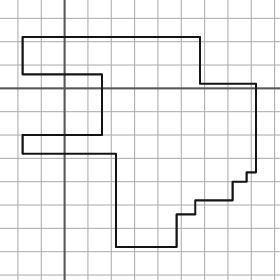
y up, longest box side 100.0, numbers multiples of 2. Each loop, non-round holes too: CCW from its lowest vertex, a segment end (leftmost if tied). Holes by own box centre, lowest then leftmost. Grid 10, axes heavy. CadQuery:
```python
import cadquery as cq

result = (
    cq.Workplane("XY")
    .moveTo(22.0, -68.0)
    .lineTo(48.0, -68.0)
    .lineTo(48.0, -54.0)
    .lineTo(56.0, -54.0)
    .lineTo(56.0, -48.0)
    .lineTo(72.0, -48.0)
    .lineTo(72.0, -40.0)
    .lineTo(78.0, -40.0)
    .lineTo(78.0, -36.0)
    .lineTo(82.0, -36.0)
    .lineTo(82.0, 2.0)
    .lineTo(58.0, 2.0)
    .lineTo(58.0, 22.0)
    .lineTo(-18.0, 22.0)
    .lineTo(-18.0, 6.0)
    .lineTo(16.0, 6.0)
    .lineTo(16.0, -20.0)
    .lineTo(-18.0, -20.0)
    .lineTo(-18.0, -28.0)
    .lineTo(22.0, -28.0)
    .close()
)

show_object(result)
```